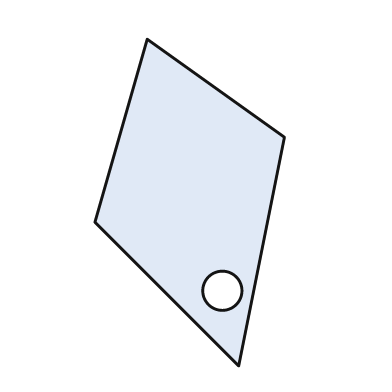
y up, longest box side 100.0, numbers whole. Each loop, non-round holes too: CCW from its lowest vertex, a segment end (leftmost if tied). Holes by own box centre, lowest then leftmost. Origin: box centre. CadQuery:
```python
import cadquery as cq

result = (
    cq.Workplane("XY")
    .moveTo(15.0, -50.0)
    .lineTo(29.0, 20.0)
    .lineTo(-13.0, 50.0)
    .lineTo(-29.0, -6.0)
    .close()
    .moveTo(10.0, -27.0)
    .circle(6.0)
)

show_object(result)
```